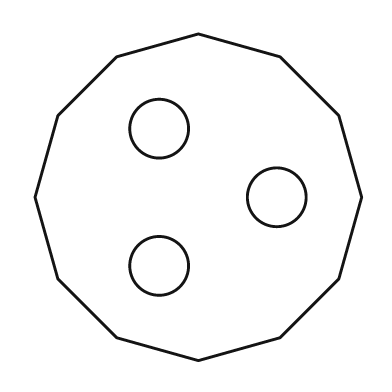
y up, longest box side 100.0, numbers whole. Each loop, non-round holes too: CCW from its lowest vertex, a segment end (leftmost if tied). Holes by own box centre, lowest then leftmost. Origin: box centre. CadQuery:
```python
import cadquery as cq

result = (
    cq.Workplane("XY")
    .moveTo(0.0, -50.0)
    .lineTo(25.0, -43.0)
    .lineTo(43.0, -25.0)
    .lineTo(50.0, 0.0)
    .lineTo(43.0, 25.0)
    .lineTo(25.0, 43.0)
    .lineTo(0.0, 50.0)
    .lineTo(-25.0, 43.0)
    .lineTo(-43.0, 25.0)
    .lineTo(-50.0, 0.0)
    .lineTo(-43.0, -25.0)
    .lineTo(-25.0, -43.0)
    .close()
    .moveTo(-12.0, -21.0)
    .circle(9.0)
    .moveTo(24.0, 0.0)
    .circle(9.0)
    .moveTo(-12.0, 21.0)
    .circle(9.0)
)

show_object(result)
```